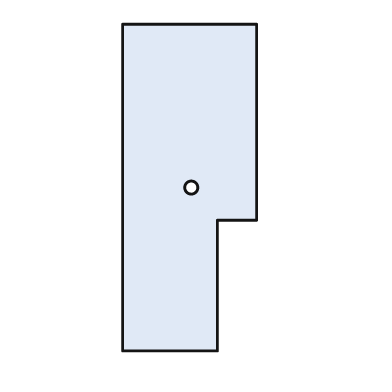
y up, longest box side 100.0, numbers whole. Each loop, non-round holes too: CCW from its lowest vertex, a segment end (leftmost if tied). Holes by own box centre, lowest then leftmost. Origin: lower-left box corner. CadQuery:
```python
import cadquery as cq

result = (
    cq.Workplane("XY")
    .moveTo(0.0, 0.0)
    .lineTo(29.0, 0.0)
    .lineTo(29.0, 40.0)
    .lineTo(41.0, 40.0)
    .lineTo(41.0, 100.0)
    .lineTo(0.0, 100.0)
    .close()
    .moveTo(21.0, 50.0)
    .circle(2.0)
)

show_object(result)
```